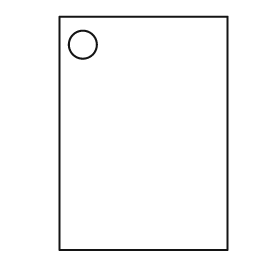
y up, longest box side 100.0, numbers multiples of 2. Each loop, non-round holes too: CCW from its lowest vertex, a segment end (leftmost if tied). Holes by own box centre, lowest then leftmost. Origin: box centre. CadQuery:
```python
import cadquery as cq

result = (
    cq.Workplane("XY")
    .moveTo(-36.0, -50.0)
    .lineTo(36.0, -50.0)
    .lineTo(36.0, 50.0)
    .lineTo(-36.0, 50.0)
    .close()
    .moveTo(-26.0, 38.0)
    .circle(6.0)
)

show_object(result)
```